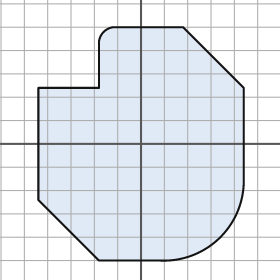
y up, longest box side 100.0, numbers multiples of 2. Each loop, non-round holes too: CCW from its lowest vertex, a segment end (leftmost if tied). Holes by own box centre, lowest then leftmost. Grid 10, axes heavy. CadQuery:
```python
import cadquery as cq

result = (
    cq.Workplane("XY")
    .moveTo(-18.0, -50.0)
    .lineTo(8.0, -50.0)
    .threePointArc((34.0, -40.0), (44.0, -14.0))
    .lineTo(44.0, 24.0)
    .lineTo(18.0, 50.0)
    .lineTo(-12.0, 50.0)
    .threePointArc((-16.0, 48.0), (-18.0, 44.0))
    .lineTo(-18.0, 24.0)
    .lineTo(-44.0, 24.0)
    .lineTo(-44.0, -24.0)
    .close()
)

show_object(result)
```